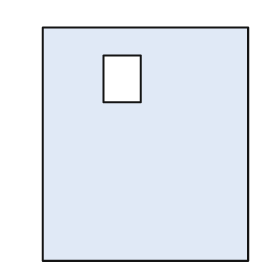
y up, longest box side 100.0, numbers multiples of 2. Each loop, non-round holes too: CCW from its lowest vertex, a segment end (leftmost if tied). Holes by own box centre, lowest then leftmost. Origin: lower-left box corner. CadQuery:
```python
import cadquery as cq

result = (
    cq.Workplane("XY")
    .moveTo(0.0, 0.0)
    .lineTo(88.0, 0.0)
    .lineTo(88.0, 100.0)
    .lineTo(0.0, 100.0)
    .close()
    .moveTo(26.0, 68.0)
    .lineTo(42.0, 68.0)
    .lineTo(42.0, 88.0)
    .lineTo(26.0, 88.0)
    .close()
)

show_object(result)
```